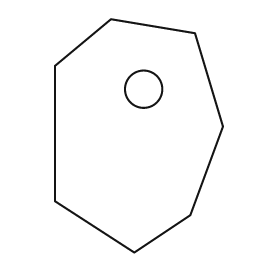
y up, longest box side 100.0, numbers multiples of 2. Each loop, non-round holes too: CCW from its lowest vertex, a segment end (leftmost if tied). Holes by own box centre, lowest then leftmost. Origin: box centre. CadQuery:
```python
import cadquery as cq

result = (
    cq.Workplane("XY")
    .moveTo(-2.0, -50.0)
    .lineTo(22.0, -34.0)
    .lineTo(36.0, 4.0)
    .lineTo(24.0, 44.0)
    .lineTo(-12.0, 50.0)
    .lineTo(-36.0, 30.0)
    .lineTo(-36.0, -28.0)
    .close()
    .moveTo(2.0, 20.0)
    .circle(8.0)
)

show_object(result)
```